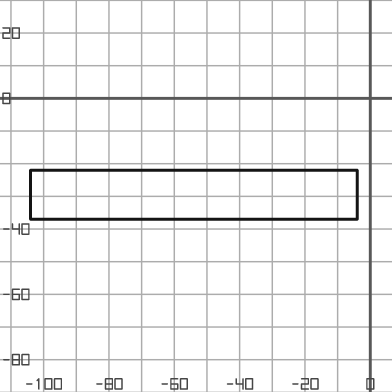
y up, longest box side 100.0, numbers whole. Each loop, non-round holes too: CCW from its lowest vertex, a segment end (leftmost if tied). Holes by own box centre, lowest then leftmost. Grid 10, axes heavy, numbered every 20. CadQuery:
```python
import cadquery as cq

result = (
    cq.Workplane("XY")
    .moveTo(-104.0, -37.0)
    .lineTo(-4.0, -37.0)
    .lineTo(-4.0, -22.0)
    .lineTo(-104.0, -22.0)
    .close()
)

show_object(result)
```